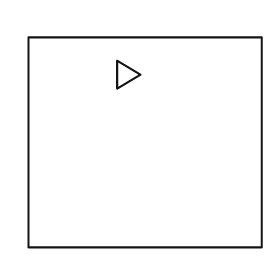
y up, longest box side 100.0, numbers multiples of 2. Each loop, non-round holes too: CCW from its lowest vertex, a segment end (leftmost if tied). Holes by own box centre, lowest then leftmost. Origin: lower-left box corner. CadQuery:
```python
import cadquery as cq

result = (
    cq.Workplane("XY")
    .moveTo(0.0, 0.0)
    .lineTo(100.0, 0.0)
    .lineTo(100.0, 90.0)
    .lineTo(0.0, 90.0)
    .close()
    .moveTo(38.0, 68.0)
    .lineTo(48.0, 74.0)
    .lineTo(38.0, 80.0)
    .close()
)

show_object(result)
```